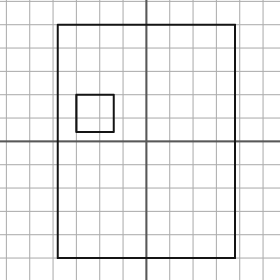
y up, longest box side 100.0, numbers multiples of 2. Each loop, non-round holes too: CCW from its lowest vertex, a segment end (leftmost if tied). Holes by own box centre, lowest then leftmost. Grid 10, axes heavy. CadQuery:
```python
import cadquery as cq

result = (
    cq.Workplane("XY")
    .moveTo(-38.0, -50.0)
    .lineTo(38.0, -50.0)
    .lineTo(38.0, 50.0)
    .lineTo(-38.0, 50.0)
    .close()
    .moveTo(-30.0, 4.0)
    .lineTo(-14.0, 4.0)
    .lineTo(-14.0, 20.0)
    .lineTo(-30.0, 20.0)
    .close()
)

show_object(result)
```